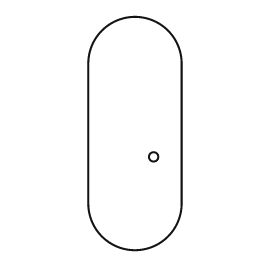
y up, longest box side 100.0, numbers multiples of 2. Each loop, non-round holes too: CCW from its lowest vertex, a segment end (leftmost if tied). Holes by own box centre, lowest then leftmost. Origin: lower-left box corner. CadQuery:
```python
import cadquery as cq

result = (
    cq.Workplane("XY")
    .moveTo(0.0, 20.0)
    .threePointArc((20.0, 0.0), (40.0, 20.0))
    .lineTo(40.0, 80.0)
    .threePointArc((20.0, 100.0), (0.0, 80.0))
    .close()
    .moveTo(28.0, 40.0)
    .circle(2.0)
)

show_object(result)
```